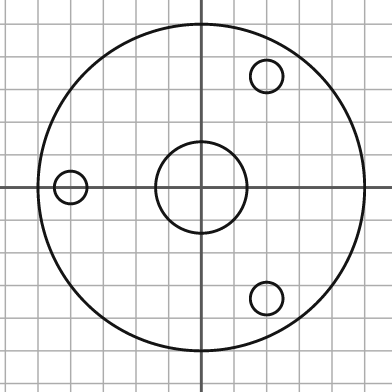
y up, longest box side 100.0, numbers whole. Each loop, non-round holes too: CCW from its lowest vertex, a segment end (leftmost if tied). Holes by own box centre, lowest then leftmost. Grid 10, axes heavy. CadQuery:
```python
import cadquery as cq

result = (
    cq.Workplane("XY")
    .moveTo(0.0, 0.0)
    .circle(50.0)
    .moveTo(20.0, -34.0)
    .circle(5.0)
    .moveTo(-40.0, 0.0)
    .circle(5.0)
    .moveTo(0.0, 0.0)
    .circle(14.0)
    .moveTo(20.0, 34.0)
    .circle(5.0)
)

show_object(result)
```